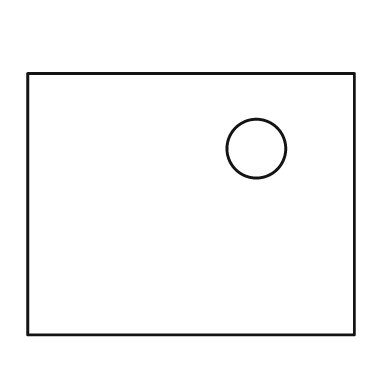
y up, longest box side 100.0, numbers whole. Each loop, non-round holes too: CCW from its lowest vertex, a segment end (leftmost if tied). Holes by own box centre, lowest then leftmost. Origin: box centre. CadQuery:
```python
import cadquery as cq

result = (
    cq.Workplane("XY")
    .moveTo(-50.0, -40.0)
    .lineTo(50.0, -40.0)
    .lineTo(50.0, 40.0)
    .lineTo(-50.0, 40.0)
    .close()
    .moveTo(20.0, 17.0)
    .circle(9.0)
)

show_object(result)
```